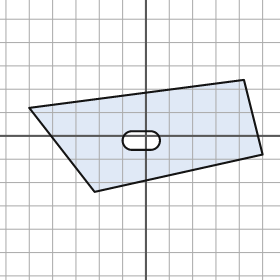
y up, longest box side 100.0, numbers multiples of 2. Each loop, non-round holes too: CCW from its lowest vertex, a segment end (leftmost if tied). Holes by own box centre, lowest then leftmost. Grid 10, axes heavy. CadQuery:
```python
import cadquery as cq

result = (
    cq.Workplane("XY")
    .moveTo(-22.0, -24.0)
    .lineTo(50.0, -8.0)
    .lineTo(42.0, 24.0)
    .lineTo(-50.0, 12.0)
    .close()
    .moveTo(-6.0, -6.0)
    .lineTo(2.0, -6.0)
    .threePointArc((6.0, -2.0), (2.0, 2.0))
    .lineTo(-6.0, 2.0)
    .threePointArc((-10.0, -2.0), (-6.0, -6.0))
    .close()
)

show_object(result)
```